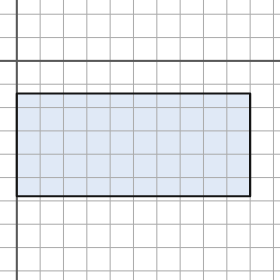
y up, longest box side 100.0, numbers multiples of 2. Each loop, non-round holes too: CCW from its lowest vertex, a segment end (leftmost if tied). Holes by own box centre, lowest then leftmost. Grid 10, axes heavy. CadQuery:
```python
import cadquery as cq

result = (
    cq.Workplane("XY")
    .moveTo(0.0, -58.0)
    .lineTo(100.0, -58.0)
    .lineTo(100.0, -14.0)
    .lineTo(0.0, -14.0)
    .close()
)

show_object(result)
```